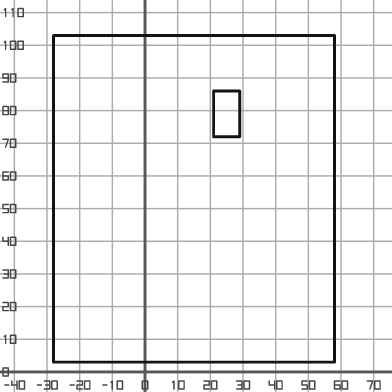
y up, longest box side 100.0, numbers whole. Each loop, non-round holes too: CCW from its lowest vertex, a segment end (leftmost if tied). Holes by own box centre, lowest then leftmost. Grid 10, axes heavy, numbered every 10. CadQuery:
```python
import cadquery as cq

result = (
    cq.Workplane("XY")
    .moveTo(-28.0, 3.0)
    .lineTo(58.0, 3.0)
    .lineTo(58.0, 103.0)
    .lineTo(-28.0, 103.0)
    .close()
    .moveTo(21.0, 72.0)
    .lineTo(29.0, 72.0)
    .lineTo(29.0, 86.0)
    .lineTo(21.0, 86.0)
    .close()
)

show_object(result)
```